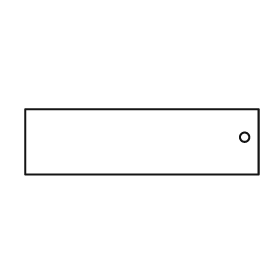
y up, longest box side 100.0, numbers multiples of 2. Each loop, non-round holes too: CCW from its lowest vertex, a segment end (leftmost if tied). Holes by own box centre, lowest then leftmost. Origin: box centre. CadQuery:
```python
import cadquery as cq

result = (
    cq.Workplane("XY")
    .moveTo(-50.0, -14.0)
    .lineTo(50.0, -14.0)
    .lineTo(50.0, 14.0)
    .lineTo(-50.0, 14.0)
    .close()
    .moveTo(44.0, 2.0)
    .circle(2.0)
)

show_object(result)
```